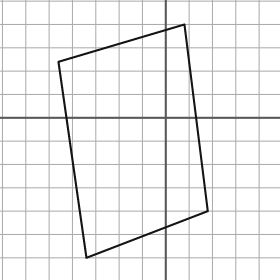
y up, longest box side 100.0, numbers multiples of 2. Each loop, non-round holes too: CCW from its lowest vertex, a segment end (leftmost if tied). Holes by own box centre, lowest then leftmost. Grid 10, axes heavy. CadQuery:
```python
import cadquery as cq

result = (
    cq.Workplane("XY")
    .moveTo(-34.0, -60.0)
    .lineTo(18.0, -40.0)
    .lineTo(8.0, 40.0)
    .lineTo(-46.0, 24.0)
    .close()
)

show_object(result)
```